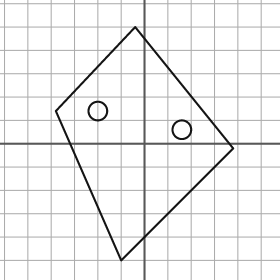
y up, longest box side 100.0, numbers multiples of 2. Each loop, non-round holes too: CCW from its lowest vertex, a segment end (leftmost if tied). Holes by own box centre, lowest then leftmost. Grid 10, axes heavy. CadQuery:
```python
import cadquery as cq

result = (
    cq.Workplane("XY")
    .moveTo(-10.0, -50.0)
    .lineTo(38.0, -2.0)
    .lineTo(-4.0, 50.0)
    .lineTo(-38.0, 14.0)
    .close()
    .moveTo(16.0, 6.0)
    .circle(4.0)
    .moveTo(-20.0, 14.0)
    .circle(4.0)
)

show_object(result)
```